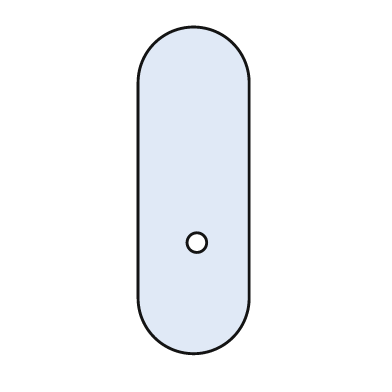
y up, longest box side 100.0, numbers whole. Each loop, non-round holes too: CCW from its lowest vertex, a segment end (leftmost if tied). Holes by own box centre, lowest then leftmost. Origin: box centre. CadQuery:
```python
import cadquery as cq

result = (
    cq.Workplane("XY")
    .moveTo(-17.0, -33.0)
    .threePointArc((0.0, -50.0), (17.0, -33.0))
    .lineTo(17.0, 33.0)
    .threePointArc((0.0, 50.0), (-17.0, 33.0))
    .close()
    .moveTo(1.0, -16.0)
    .circle(3.0)
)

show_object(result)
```